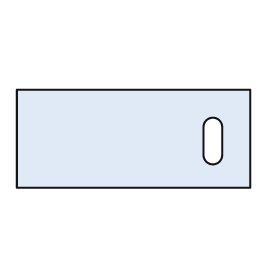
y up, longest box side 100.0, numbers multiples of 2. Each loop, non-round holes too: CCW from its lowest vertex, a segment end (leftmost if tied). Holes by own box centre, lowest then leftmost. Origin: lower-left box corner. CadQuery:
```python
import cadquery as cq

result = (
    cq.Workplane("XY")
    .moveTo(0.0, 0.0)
    .lineTo(100.0, 0.0)
    .lineTo(100.0, 42.0)
    .lineTo(0.0, 42.0)
    .close()
    .moveTo(80.0, 14.0)
    .threePointArc((84.0, 10.0), (88.0, 14.0))
    .lineTo(88.0, 26.0)
    .threePointArc((84.0, 30.0), (80.0, 26.0))
    .close()
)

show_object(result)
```